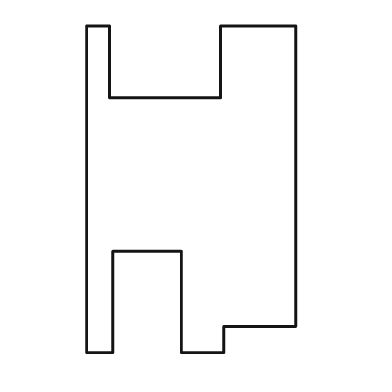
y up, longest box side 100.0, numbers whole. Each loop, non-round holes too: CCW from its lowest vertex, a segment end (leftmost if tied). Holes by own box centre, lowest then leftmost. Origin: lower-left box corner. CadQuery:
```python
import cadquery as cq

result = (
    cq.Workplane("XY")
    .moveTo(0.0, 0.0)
    .lineTo(8.0, 0.0)
    .lineTo(8.0, 31.0)
    .lineTo(29.0, 31.0)
    .lineTo(29.0, 0.0)
    .lineTo(42.0, 0.0)
    .lineTo(42.0, 8.0)
    .lineTo(64.0, 8.0)
    .lineTo(64.0, 100.0)
    .lineTo(41.0, 100.0)
    .lineTo(41.0, 78.0)
    .lineTo(7.0, 78.0)
    .lineTo(7.0, 100.0)
    .lineTo(0.0, 100.0)
    .close()
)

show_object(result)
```